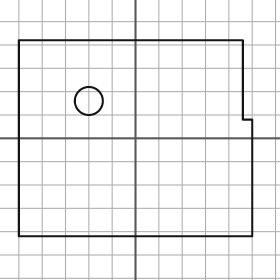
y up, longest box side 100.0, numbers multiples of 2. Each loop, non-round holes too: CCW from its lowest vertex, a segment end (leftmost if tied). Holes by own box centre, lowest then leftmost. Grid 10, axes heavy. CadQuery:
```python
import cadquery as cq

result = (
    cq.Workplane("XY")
    .moveTo(-50.0, -42.0)
    .lineTo(50.0, -42.0)
    .lineTo(50.0, 8.0)
    .lineTo(46.0, 8.0)
    .lineTo(46.0, 42.0)
    .lineTo(-50.0, 42.0)
    .close()
    .moveTo(-20.0, 16.0)
    .circle(6.0)
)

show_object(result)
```